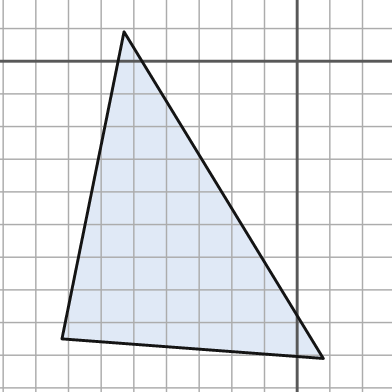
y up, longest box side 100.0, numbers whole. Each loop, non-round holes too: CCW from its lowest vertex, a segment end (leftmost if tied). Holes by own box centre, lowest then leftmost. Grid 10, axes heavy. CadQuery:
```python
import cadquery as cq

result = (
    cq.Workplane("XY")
    .moveTo(8.0, -91.0)
    .lineTo(-53.0, 9.0)
    .lineTo(-72.0, -85.0)
    .close()
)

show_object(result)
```